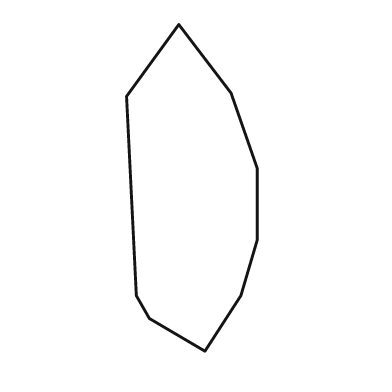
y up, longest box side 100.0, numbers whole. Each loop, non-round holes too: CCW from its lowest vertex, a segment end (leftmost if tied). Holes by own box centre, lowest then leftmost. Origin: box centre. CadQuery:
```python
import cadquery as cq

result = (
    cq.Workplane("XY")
    .moveTo(4.0, -50.0)
    .lineTo(15.0, -33.0)
    .lineTo(20.0, -16.0)
    .lineTo(20.0, 6.0)
    .lineTo(12.0, 29.0)
    .lineTo(-4.0, 50.0)
    .lineTo(-20.0, 28.0)
    .lineTo(-17.0, -33.0)
    .lineTo(-13.0, -40.0)
    .close()
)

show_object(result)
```